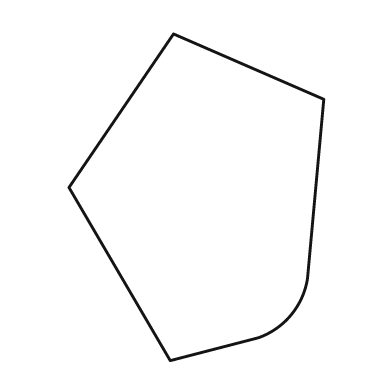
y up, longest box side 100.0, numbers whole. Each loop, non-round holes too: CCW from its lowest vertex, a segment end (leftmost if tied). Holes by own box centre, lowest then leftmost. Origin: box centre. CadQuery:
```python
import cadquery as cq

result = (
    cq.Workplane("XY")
    .moveTo(-8.0, -50.0)
    .lineTo(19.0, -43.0)
    .threePointArc((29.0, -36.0), (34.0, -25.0))
    .lineTo(39.0, 30.0)
    .lineTo(-7.0, 50.0)
    .lineTo(-39.0, 3.0)
    .close()
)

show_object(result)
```